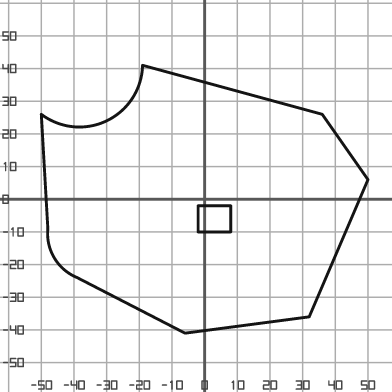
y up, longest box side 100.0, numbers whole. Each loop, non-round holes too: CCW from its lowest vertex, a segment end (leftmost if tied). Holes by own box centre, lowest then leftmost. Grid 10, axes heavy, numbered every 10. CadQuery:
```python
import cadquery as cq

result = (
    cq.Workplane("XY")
    .moveTo(-6.0, -41.0)
    .lineTo(32.0, -36.0)
    .lineTo(50.0, 6.0)
    .lineTo(36.0, 26.0)
    .lineTo(-19.0, 41.0)
    .threePointArc((-30.0, 24.0), (-50.0, 26.0))
    .lineTo(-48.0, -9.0)
    .threePointArc((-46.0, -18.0), (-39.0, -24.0))
    .close()
    .moveTo(-2.0, -10.0)
    .lineTo(8.0, -10.0)
    .lineTo(8.0, -2.0)
    .lineTo(-2.0, -2.0)
    .close()
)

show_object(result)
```